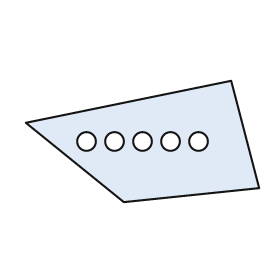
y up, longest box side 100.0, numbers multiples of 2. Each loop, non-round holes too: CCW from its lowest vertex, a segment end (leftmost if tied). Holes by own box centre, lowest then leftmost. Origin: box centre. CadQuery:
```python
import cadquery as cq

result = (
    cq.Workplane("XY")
    .moveTo(-8.0, -26.0)
    .lineTo(50.0, -20.0)
    .lineTo(38.0, 26.0)
    .lineTo(-50.0, 8.0)
    .close()
    .moveTo(-24.0, 0.0)
    .circle(4.0)
    .moveTo(-12.0, 0.0)
    .circle(4.0)
    .moveTo(0.0, 0.0)
    .circle(4.0)
    .moveTo(12.0, 0.0)
    .circle(4.0)
    .moveTo(24.0, 0.0)
    .circle(4.0)
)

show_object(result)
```